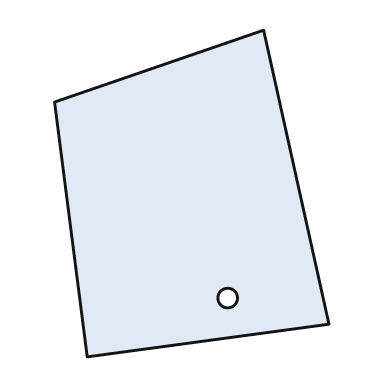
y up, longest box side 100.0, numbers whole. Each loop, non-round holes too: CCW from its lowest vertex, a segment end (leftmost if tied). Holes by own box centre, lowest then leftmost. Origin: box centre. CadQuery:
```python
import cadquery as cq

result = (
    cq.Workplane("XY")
    .moveTo(-32.0, -50.0)
    .lineTo(42.0, -40.0)
    .lineTo(22.0, 50.0)
    .lineTo(-42.0, 28.0)
    .close()
    .moveTo(11.0, -32.0)
    .circle(3.0)
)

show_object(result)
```